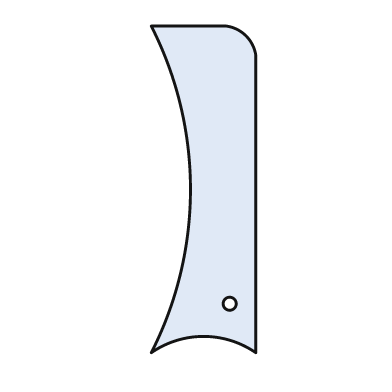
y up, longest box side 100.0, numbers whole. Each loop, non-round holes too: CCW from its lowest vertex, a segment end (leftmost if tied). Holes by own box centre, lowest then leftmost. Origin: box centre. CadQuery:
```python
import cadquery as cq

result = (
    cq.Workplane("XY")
    .moveTo(-16.0, -50.0)
    .threePointArc((0.0, -45.0), (16.0, -50.0))
    .lineTo(16.0, 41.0)
    .threePointArc((13.0, 47.0), (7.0, 50.0))
    .lineTo(-16.0, 50.0)
    .threePointArc((-4.0, 0.0), (-16.0, -50.0))
    .close()
    .moveTo(8.0, -35.0)
    .circle(2.0)
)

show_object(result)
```